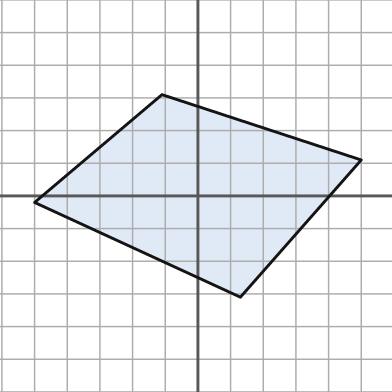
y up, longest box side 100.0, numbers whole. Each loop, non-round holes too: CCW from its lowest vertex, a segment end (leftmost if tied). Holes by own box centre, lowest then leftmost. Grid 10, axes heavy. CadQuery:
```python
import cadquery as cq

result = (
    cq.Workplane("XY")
    .moveTo(13.0, -31.0)
    .lineTo(50.0, 11.0)
    .lineTo(-11.0, 31.0)
    .lineTo(-50.0, -2.0)
    .close()
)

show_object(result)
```